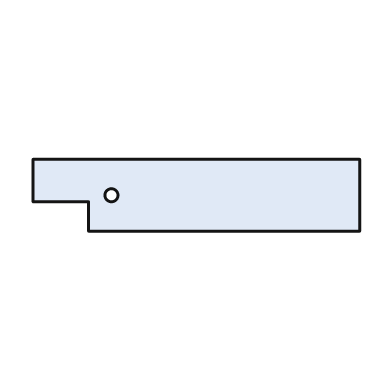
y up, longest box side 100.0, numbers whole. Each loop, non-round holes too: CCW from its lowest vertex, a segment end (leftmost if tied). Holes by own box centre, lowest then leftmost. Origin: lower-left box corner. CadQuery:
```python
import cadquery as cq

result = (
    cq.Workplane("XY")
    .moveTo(17.0, 0.0)
    .lineTo(100.0, 0.0)
    .lineTo(100.0, 22.0)
    .lineTo(0.0, 22.0)
    .lineTo(0.0, 9.0)
    .lineTo(17.0, 9.0)
    .close()
    .moveTo(24.0, 11.0)
    .circle(2.0)
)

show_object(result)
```